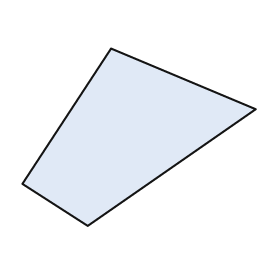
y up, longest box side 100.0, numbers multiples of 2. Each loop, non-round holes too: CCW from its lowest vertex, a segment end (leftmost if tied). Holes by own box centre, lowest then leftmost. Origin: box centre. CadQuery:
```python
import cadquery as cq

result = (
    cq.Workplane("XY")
    .moveTo(-22.0, -38.0)
    .lineTo(50.0, 12.0)
    .lineTo(-12.0, 38.0)
    .lineTo(-50.0, -20.0)
    .close()
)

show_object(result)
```